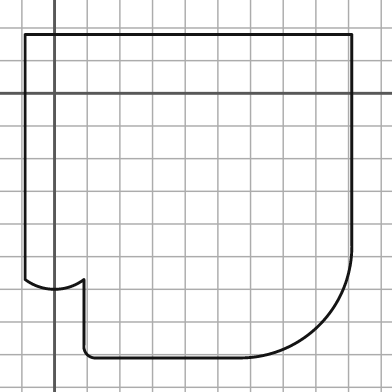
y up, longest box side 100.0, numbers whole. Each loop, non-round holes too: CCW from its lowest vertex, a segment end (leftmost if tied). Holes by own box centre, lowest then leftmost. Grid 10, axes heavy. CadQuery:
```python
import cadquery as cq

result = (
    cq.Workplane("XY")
    .moveTo(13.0, -81.0)
    .lineTo(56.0, -81.0)
    .threePointArc((81.0, -71.0), (91.0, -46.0))
    .lineTo(91.0, 18.0)
    .lineTo(-9.0, 18.0)
    .lineTo(-9.0, -57.0)
    .threePointArc((0.0, -60.0), (9.0, -57.0))
    .lineTo(9.0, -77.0)
    .threePointArc((10.0, -80.0), (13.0, -81.0))
    .close()
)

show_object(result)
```